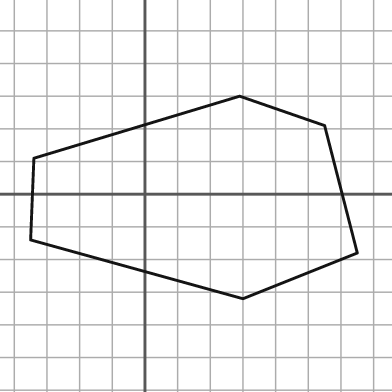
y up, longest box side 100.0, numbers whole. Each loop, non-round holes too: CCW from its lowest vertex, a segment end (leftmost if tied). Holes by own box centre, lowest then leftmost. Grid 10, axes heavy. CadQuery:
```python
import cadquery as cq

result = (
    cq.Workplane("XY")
    .moveTo(30.0, -32.0)
    .lineTo(65.0, -18.0)
    .lineTo(55.0, 21.0)
    .lineTo(29.0, 30.0)
    .lineTo(-34.0, 11.0)
    .lineTo(-35.0, -14.0)
    .close()
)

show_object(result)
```